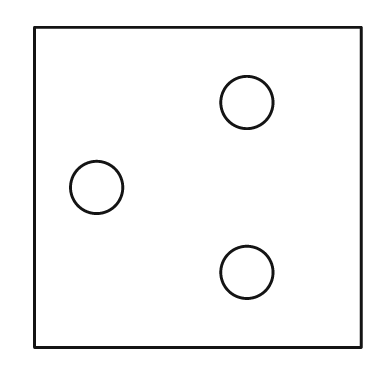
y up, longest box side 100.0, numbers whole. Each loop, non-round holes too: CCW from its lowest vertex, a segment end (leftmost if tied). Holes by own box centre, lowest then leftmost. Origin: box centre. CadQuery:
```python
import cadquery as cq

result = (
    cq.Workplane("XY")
    .moveTo(-50.0, -49.0)
    .lineTo(50.0, -49.0)
    .lineTo(50.0, 49.0)
    .lineTo(-50.0, 49.0)
    .close()
    .moveTo(15.0, -26.0)
    .circle(8.0)
    .moveTo(-31.0, 0.0)
    .circle(8.0)
    .moveTo(15.0, 26.0)
    .circle(8.0)
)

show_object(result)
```